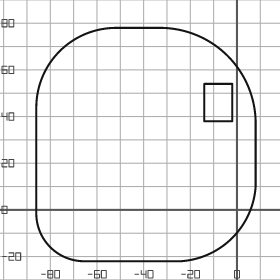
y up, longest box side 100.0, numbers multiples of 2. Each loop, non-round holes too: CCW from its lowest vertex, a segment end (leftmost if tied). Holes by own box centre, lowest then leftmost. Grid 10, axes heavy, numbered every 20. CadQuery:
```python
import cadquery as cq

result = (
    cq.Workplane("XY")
    .moveTo(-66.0, -22.0)
    .lineTo(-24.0, -22.0)
    .threePointArc((-2.0, -12.0), (8.0, 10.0))
    .lineTo(8.0, 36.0)
    .threePointArc((-4.0, 66.0), (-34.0, 78.0))
    .lineTo(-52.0, 78.0)
    .threePointArc((-76.0, 68.0), (-86.0, 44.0))
    .lineTo(-86.0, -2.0)
    .threePointArc((-80.0, -16.0), (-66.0, -22.0))
    .close()
    .moveTo(-14.0, 38.0)
    .lineTo(-2.0, 38.0)
    .lineTo(-2.0, 54.0)
    .lineTo(-14.0, 54.0)
    .close()
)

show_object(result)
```